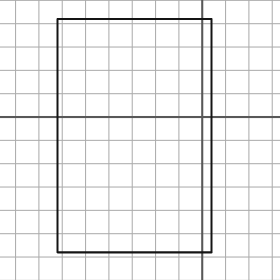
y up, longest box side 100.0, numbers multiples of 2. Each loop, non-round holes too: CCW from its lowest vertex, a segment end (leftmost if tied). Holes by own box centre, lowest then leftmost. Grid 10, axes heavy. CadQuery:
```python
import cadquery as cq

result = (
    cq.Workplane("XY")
    .moveTo(-62.0, -58.0)
    .lineTo(4.0, -58.0)
    .lineTo(4.0, 42.0)
    .lineTo(-62.0, 42.0)
    .close()
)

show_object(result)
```